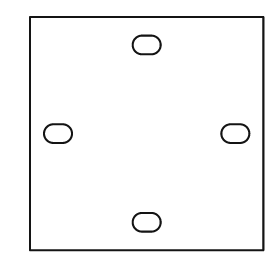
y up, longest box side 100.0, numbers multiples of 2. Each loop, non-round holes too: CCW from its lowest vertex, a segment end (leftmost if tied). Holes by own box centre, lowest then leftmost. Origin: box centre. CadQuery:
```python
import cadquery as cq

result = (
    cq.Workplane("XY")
    .moveTo(-50.0, -50.0)
    .lineTo(50.0, -50.0)
    .lineTo(50.0, 50.0)
    .lineTo(-50.0, 50.0)
    .close()
    .moveTo(-2.0, -42.0)
    .lineTo(2.0, -42.0)
    .threePointArc((6.0, -38.0), (2.0, -34.0))
    .lineTo(-2.0, -34.0)
    .threePointArc((-6.0, -38.0), (-2.0, -42.0))
    .close()
    .moveTo(-40.0, -4.0)
    .lineTo(-36.0, -4.0)
    .threePointArc((-32.0, 0.0), (-36.0, 4.0))
    .lineTo(-40.0, 4.0)
    .threePointArc((-44.0, 0.0), (-40.0, -4.0))
    .close()
    .moveTo(36.0, -4.0)
    .lineTo(40.0, -4.0)
    .threePointArc((44.0, 0.0), (40.0, 4.0))
    .lineTo(36.0, 4.0)
    .threePointArc((32.0, 0.0), (36.0, -4.0))
    .close()
    .moveTo(-2.0, 34.0)
    .lineTo(2.0, 34.0)
    .threePointArc((6.0, 38.0), (2.0, 42.0))
    .lineTo(-2.0, 42.0)
    .threePointArc((-6.0, 38.0), (-2.0, 34.0))
    .close()
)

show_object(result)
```